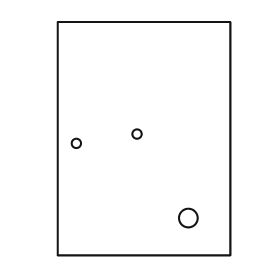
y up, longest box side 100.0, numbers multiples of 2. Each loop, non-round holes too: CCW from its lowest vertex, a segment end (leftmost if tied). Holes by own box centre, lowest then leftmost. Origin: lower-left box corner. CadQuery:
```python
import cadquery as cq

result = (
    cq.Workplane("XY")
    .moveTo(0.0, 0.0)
    .lineTo(74.0, 0.0)
    .lineTo(74.0, 100.0)
    .lineTo(0.0, 100.0)
    .close()
    .moveTo(56.0, 16.0)
    .circle(4.0)
    .moveTo(8.0, 48.0)
    .circle(2.0)
    .moveTo(34.0, 52.0)
    .circle(2.0)
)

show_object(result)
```